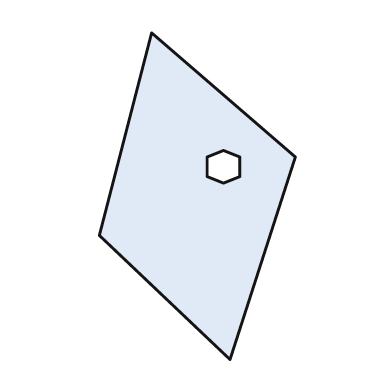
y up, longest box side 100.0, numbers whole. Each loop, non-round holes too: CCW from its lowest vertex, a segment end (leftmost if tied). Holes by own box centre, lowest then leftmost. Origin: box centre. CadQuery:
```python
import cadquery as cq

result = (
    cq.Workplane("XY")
    .moveTo(10.0, -50.0)
    .lineTo(30.0, 12.0)
    .lineTo(-14.0, 50.0)
    .lineTo(-30.0, -12.0)
    .close()
    .moveTo(8.0, 4.0)
    .lineTo(13.0, 6.0)
    .lineTo(13.0, 12.0)
    .lineTo(8.0, 14.0)
    .lineTo(3.0, 12.0)
    .lineTo(3.0, 6.0)
    .close()
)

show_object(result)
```